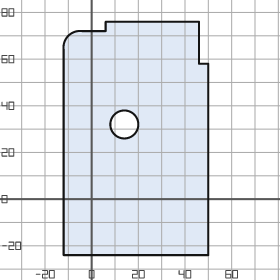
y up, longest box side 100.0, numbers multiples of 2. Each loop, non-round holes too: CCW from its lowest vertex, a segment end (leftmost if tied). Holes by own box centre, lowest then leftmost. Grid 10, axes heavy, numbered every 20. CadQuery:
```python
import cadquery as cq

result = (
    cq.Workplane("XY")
    .moveTo(-12.0, -24.0)
    .lineTo(50.0, -24.0)
    .lineTo(50.0, 58.0)
    .lineTo(46.0, 58.0)
    .lineTo(46.0, 76.0)
    .lineTo(6.0, 76.0)
    .lineTo(6.0, 72.0)
    .lineTo(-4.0, 72.0)
    .threePointArc((-10.0, 70.0), (-12.0, 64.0))
    .close()
    .moveTo(14.0, 32.0)
    .circle(6.0)
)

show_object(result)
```